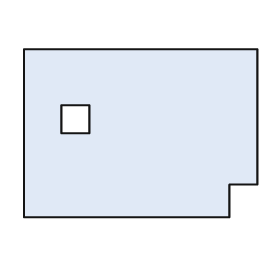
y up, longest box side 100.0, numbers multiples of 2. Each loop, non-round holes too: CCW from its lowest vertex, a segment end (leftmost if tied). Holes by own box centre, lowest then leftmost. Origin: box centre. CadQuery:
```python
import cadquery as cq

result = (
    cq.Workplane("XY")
    .moveTo(-50.0, -36.0)
    .lineTo(38.0, -36.0)
    .lineTo(38.0, -22.0)
    .lineTo(50.0, -22.0)
    .lineTo(50.0, 36.0)
    .lineTo(-50.0, 36.0)
    .close()
    .moveTo(-34.0, 0.0)
    .lineTo(-22.0, 0.0)
    .lineTo(-22.0, 12.0)
    .lineTo(-34.0, 12.0)
    .close()
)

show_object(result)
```